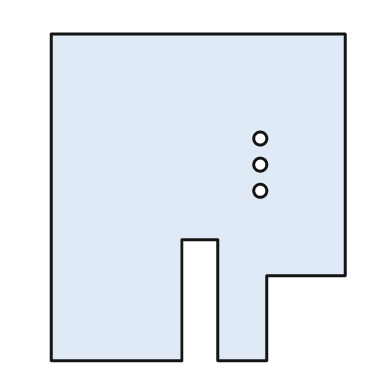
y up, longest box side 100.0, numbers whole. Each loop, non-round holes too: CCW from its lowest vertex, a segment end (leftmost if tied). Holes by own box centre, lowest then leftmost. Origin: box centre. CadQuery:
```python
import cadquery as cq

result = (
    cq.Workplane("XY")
    .moveTo(-45.0, -50.0)
    .lineTo(-5.0, -50.0)
    .lineTo(-5.0, -13.0)
    .lineTo(6.0, -13.0)
    .lineTo(6.0, -50.0)
    .lineTo(21.0, -50.0)
    .lineTo(21.0, -24.0)
    .lineTo(45.0, -24.0)
    .lineTo(45.0, 50.0)
    .lineTo(-45.0, 50.0)
    .close()
    .moveTo(19.0, 2.0)
    .circle(2.0)
    .moveTo(19.0, 10.0)
    .circle(2.0)
    .moveTo(19.0, 18.0)
    .circle(2.0)
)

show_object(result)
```